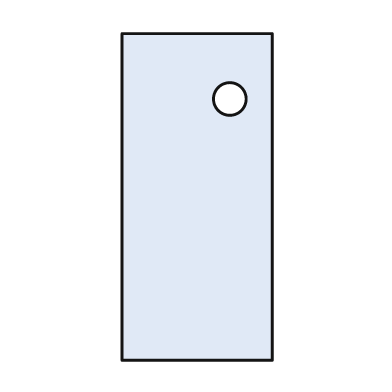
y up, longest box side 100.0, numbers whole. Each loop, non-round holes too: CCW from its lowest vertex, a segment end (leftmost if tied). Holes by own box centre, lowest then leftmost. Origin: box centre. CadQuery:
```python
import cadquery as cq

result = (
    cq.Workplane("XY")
    .moveTo(-23.0, -50.0)
    .lineTo(23.0, -50.0)
    .lineTo(23.0, 50.0)
    .lineTo(-23.0, 50.0)
    .close()
    .moveTo(10.0, 30.0)
    .circle(5.0)
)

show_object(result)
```